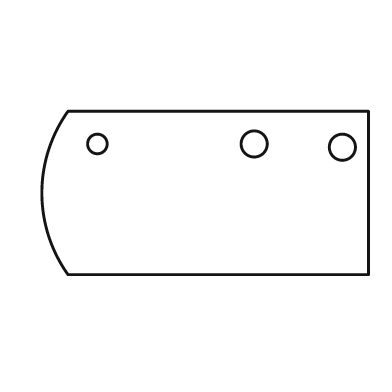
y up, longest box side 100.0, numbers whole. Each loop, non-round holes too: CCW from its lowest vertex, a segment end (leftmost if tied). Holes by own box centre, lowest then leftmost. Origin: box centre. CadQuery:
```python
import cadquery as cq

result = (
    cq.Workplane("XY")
    .moveTo(-42.0, -25.0)
    .lineTo(50.0, -25.0)
    .lineTo(50.0, 25.0)
    .lineTo(-42.0, 25.0)
    .threePointArc((-50.0, 0.0), (-42.0, -25.0))
    .close()
    .moveTo(42.0, 14.0)
    .circle(4.0)
    .moveTo(-33.0, 15.0)
    .circle(3.0)
    .moveTo(15.0, 15.0)
    .circle(4.0)
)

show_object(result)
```